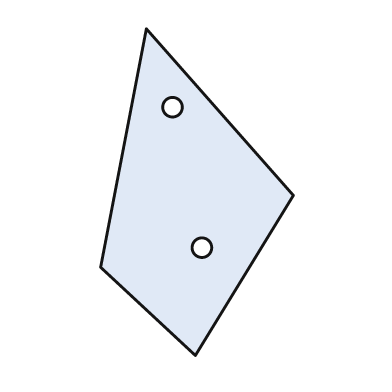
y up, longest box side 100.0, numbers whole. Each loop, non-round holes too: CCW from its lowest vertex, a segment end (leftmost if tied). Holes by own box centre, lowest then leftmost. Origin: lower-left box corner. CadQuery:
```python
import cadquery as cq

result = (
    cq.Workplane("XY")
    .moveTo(29.0, 0.0)
    .lineTo(59.0, 49.0)
    .lineTo(14.0, 100.0)
    .lineTo(0.0, 27.0)
    .close()
    .moveTo(31.0, 33.0)
    .circle(3.0)
    .moveTo(22.0, 76.0)
    .circle(3.0)
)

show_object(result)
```